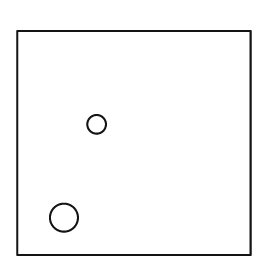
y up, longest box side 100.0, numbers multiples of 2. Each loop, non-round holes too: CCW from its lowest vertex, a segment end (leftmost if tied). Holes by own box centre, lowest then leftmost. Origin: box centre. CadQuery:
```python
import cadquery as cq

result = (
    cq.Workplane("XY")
    .moveTo(-50.0, -48.0)
    .lineTo(50.0, -48.0)
    .lineTo(50.0, 48.0)
    .lineTo(-50.0, 48.0)
    .close()
    .moveTo(-30.0, -32.0)
    .circle(6.0)
    .moveTo(-16.0, 8.0)
    .circle(4.0)
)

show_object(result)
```